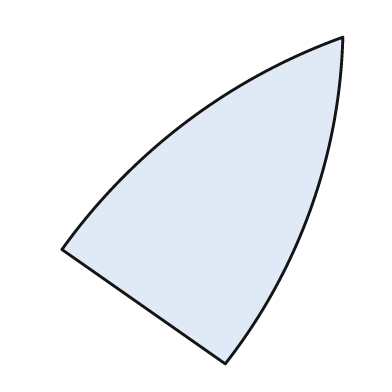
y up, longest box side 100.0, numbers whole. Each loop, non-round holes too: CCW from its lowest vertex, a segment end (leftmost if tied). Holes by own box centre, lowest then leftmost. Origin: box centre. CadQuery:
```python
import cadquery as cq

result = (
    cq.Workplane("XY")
    .moveTo(7.0, -50.0)
    .threePointArc((33.0, -3.0), (43.0, 50.0))
    .threePointArc((-5.0, 24.0), (-43.0, -15.0))
    .close()
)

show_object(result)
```